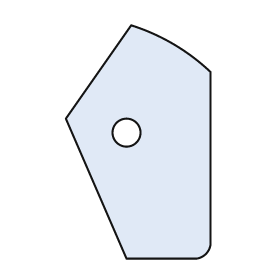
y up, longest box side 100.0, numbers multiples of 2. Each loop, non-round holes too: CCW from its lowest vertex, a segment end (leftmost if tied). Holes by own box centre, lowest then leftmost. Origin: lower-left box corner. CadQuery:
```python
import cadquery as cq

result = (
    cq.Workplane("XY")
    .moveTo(26.0, 0.0)
    .lineTo(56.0, 0.0)
    .threePointArc((60.0, 2.0), (62.0, 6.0))
    .lineTo(62.0, 80.0)
    .threePointArc((46.0, 92.0), (28.0, 100.0))
    .lineTo(0.0, 60.0)
    .close()
    .moveTo(26.0, 54.0)
    .circle(6.0)
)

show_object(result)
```